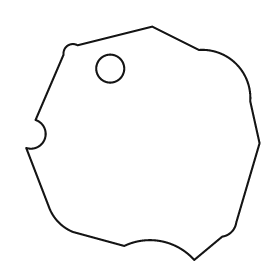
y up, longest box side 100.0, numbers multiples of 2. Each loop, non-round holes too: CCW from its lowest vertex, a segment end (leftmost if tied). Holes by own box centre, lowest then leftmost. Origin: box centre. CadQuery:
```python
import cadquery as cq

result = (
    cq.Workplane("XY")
    .moveTo(22.0, -50.0)
    .lineTo(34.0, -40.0)
    .threePointArc((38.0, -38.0), (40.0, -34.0))
    .lineTo(50.0, 0.0)
    .lineTo(46.0, 18.0)
    .threePointArc((40.0, 34.0), (24.0, 40.0))
    .lineTo(4.0, 50.0)
    .lineTo(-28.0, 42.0)
    .threePointArc((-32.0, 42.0), (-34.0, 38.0))
    .lineTo(-46.0, 10.0)
    .threePointArc((-42.0, 2.0), (-50.0, -2.0))
    .lineTo(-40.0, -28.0)
    .threePointArc((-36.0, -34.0), (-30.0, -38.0))
    .lineTo(-8.0, -44.0)
    .threePointArc((8.0, -42.0), (22.0, -50.0))
    .close()
    .moveTo(-14.0, 32.0)
    .circle(6.0)
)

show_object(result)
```